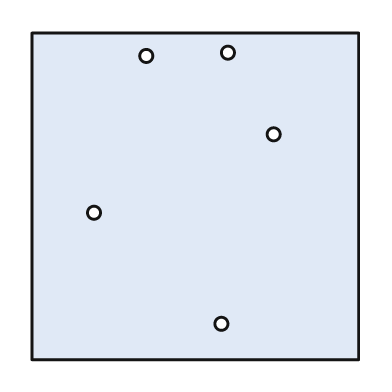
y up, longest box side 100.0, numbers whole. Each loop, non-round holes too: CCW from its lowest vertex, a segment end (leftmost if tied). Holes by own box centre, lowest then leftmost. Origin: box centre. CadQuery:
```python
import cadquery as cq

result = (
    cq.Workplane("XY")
    .moveTo(-50.0, -50.0)
    .lineTo(50.0, -50.0)
    .lineTo(50.0, 50.0)
    .lineTo(-50.0, 50.0)
    .close()
    .moveTo(8.0, -39.0)
    .circle(2.0)
    .moveTo(-31.0, -5.0)
    .circle(2.0)
    .moveTo(24.0, 19.0)
    .circle(2.0)
    .moveTo(-15.0, 43.0)
    .circle(2.0)
    .moveTo(10.0, 44.0)
    .circle(2.0)
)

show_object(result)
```